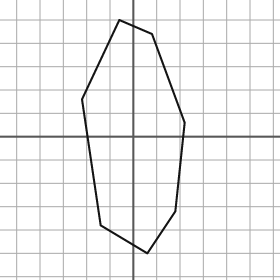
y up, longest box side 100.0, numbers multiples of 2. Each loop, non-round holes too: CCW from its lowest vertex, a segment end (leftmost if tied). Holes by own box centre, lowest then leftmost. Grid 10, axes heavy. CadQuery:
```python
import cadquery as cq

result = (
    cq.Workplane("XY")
    .moveTo(6.0, -50.0)
    .lineTo(18.0, -32.0)
    .lineTo(22.0, 6.0)
    .lineTo(8.0, 44.0)
    .lineTo(-6.0, 50.0)
    .lineTo(-22.0, 16.0)
    .lineTo(-14.0, -38.0)
    .close()
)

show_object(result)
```